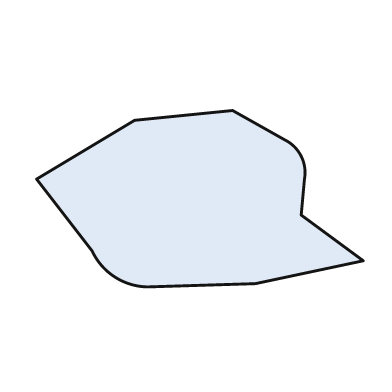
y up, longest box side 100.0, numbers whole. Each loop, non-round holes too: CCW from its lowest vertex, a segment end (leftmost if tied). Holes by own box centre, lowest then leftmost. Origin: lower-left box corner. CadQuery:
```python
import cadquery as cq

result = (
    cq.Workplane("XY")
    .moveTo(34.0, 0.0)
    .lineTo(67.0, 1.0)
    .lineTo(100.0, 8.0)
    .lineTo(81.0, 22.0)
    .lineTo(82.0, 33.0)
    .threePointArc((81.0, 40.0), (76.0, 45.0))
    .lineTo(60.0, 54.0)
    .lineTo(30.0, 51.0)
    .lineTo(0.0, 33.0)
    .lineTo(17.0, 11.0)
    .threePointArc((24.0, 3.0), (34.0, 0.0))
    .close()
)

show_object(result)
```